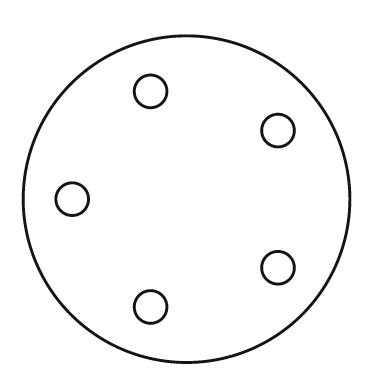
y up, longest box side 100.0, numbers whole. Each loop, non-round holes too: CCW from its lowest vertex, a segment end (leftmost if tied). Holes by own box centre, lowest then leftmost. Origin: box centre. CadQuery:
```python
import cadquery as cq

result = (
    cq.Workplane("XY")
    .moveTo(0.0, 0.0)
    .circle(50.0)
    .moveTo(-11.0, -33.0)
    .circle(5.0)
    .moveTo(28.0, -21.0)
    .circle(5.0)
    .moveTo(-35.0, 0.0)
    .circle(5.0)
    .moveTo(28.0, 21.0)
    .circle(5.0)
    .moveTo(-11.0, 33.0)
    .circle(5.0)
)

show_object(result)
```